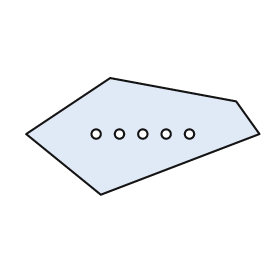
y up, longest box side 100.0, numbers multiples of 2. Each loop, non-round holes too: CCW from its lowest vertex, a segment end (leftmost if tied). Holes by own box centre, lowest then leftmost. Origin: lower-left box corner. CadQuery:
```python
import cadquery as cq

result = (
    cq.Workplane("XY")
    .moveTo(32.0, 0.0)
    .lineTo(100.0, 26.0)
    .lineTo(90.0, 40.0)
    .lineTo(36.0, 50.0)
    .lineTo(0.0, 26.0)
    .close()
    .moveTo(30.0, 26.0)
    .circle(2.0)
    .moveTo(40.0, 26.0)
    .circle(2.0)
    .moveTo(50.0, 26.0)
    .circle(2.0)
    .moveTo(60.0, 26.0)
    .circle(2.0)
    .moveTo(70.0, 26.0)
    .circle(2.0)
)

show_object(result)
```